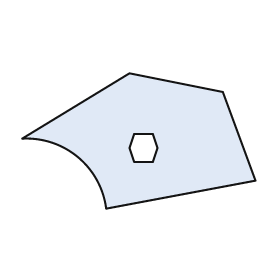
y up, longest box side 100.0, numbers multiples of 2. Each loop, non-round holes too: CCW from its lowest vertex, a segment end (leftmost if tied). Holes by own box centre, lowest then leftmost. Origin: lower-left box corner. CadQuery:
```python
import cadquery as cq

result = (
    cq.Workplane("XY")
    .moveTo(36.0, 0.0)
    .lineTo(100.0, 12.0)
    .lineTo(86.0, 50.0)
    .lineTo(46.0, 58.0)
    .lineTo(0.0, 30.0)
    .threePointArc((24.0, 22.0), (36.0, 0.0))
    .close()
    .moveTo(48.0, 20.0)
    .lineTo(56.0, 20.0)
    .lineTo(58.0, 26.0)
    .lineTo(56.0, 32.0)
    .lineTo(48.0, 32.0)
    .lineTo(46.0, 26.0)
    .close()
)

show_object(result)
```